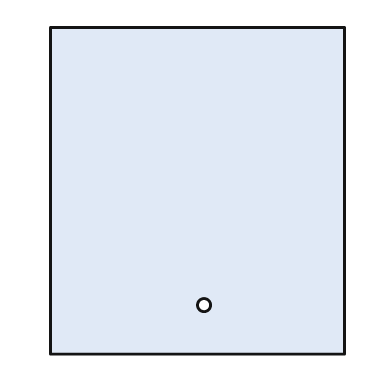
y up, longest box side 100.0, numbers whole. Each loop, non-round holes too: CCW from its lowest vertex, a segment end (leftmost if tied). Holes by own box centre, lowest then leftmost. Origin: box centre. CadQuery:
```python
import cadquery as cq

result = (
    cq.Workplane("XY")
    .moveTo(-45.0, -50.0)
    .lineTo(45.0, -50.0)
    .lineTo(45.0, 50.0)
    .lineTo(-45.0, 50.0)
    .close()
    .moveTo(2.0, -35.0)
    .circle(2.0)
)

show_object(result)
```